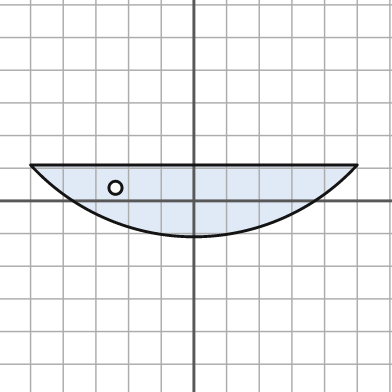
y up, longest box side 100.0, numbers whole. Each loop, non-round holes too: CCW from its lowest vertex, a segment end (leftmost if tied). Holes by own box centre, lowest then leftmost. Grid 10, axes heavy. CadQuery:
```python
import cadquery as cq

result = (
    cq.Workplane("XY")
    .moveTo(-50.0, 11.0)
    .threePointArc((0.0, -11.0), (50.0, 11.0))
    .close()
    .moveTo(-24.0, 4.0)
    .circle(2.0)
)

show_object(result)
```